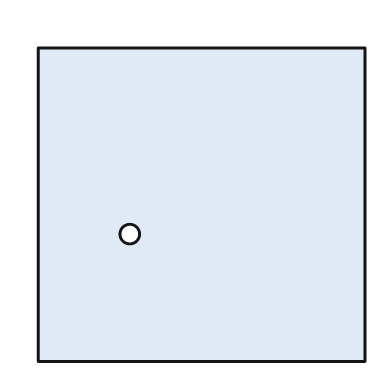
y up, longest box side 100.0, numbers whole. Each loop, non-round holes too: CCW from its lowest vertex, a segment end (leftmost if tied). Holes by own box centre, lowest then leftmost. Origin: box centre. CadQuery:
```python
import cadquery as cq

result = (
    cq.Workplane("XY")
    .moveTo(-50.0, -48.0)
    .lineTo(50.0, -48.0)
    .lineTo(50.0, 48.0)
    .lineTo(-50.0, 48.0)
    .close()
    .moveTo(-22.0, -9.0)
    .circle(3.0)
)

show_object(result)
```